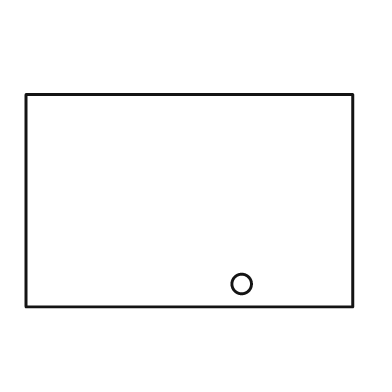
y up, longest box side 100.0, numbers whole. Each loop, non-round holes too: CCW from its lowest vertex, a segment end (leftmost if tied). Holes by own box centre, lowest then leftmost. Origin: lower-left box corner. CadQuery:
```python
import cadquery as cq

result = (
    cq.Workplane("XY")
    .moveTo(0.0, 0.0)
    .lineTo(100.0, 0.0)
    .lineTo(100.0, 65.0)
    .lineTo(0.0, 65.0)
    .close()
    .moveTo(66.0, 7.0)
    .circle(3.0)
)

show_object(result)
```